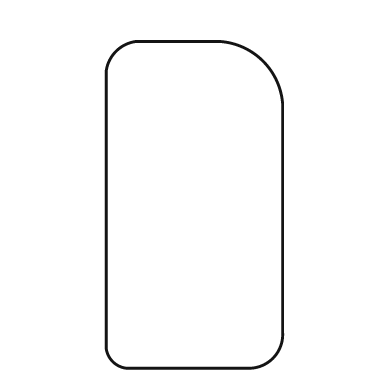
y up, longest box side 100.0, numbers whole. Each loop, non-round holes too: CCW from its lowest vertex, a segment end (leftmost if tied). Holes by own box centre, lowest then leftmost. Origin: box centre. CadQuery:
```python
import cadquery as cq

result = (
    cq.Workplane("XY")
    .moveTo(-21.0, -50.0)
    .lineTo(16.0, -50.0)
    .threePointArc((24.0, -47.0), (27.0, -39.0))
    .lineTo(27.0, 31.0)
    .threePointArc((21.0, 44.0), (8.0, 50.0))
    .lineTo(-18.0, 50.0)
    .threePointArc((-24.0, 47.0), (-27.0, 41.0))
    .lineTo(-27.0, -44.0)
    .threePointArc((-25.0, -48.0), (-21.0, -50.0))
    .close()
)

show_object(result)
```